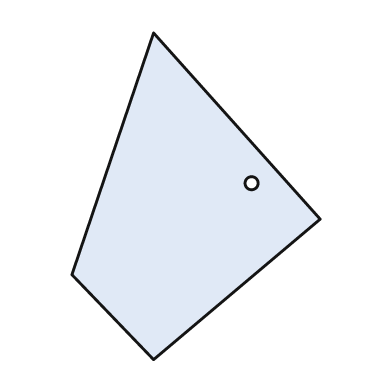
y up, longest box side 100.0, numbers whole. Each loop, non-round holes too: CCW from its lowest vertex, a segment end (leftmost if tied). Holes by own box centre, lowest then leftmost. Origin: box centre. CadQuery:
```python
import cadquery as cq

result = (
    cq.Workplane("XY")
    .moveTo(-13.0, -50.0)
    .lineTo(38.0, -7.0)
    .lineTo(-13.0, 50.0)
    .lineTo(-38.0, -24.0)
    .close()
    .moveTo(17.0, 4.0)
    .circle(2.0)
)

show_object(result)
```